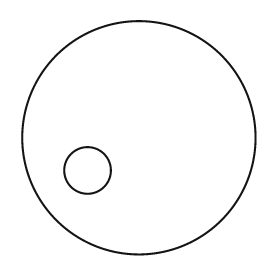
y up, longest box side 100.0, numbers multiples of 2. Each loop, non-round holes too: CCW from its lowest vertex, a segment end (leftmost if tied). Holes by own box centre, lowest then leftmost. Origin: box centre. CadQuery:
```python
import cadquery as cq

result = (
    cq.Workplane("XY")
    .moveTo(0.0, 0.0)
    .circle(50.0)
    .moveTo(-22.0, -14.0)
    .circle(10.0)
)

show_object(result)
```